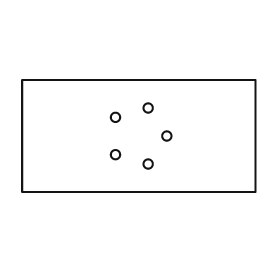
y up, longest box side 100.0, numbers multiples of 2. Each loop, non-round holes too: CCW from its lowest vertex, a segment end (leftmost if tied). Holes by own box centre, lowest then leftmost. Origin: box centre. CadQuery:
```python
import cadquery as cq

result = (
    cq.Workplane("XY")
    .moveTo(-50.0, -24.0)
    .lineTo(50.0, -24.0)
    .lineTo(50.0, 24.0)
    .lineTo(-50.0, 24.0)
    .close()
    .moveTo(4.0, -12.0)
    .circle(2.0)
    .moveTo(-10.0, -8.0)
    .circle(2.0)
    .moveTo(12.0, 0.0)
    .circle(2.0)
    .moveTo(-10.0, 8.0)
    .circle(2.0)
    .moveTo(4.0, 12.0)
    .circle(2.0)
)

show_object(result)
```